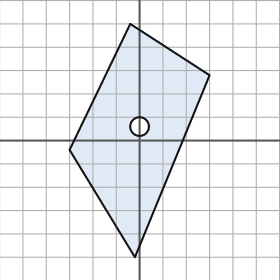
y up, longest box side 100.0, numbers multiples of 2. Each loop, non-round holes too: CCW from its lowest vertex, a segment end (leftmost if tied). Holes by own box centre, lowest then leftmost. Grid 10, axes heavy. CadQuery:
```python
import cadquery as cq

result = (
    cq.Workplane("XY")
    .moveTo(-2.0, -50.0)
    .lineTo(30.0, 28.0)
    .lineTo(-4.0, 50.0)
    .lineTo(-30.0, -4.0)
    .close()
    .moveTo(0.0, 6.0)
    .circle(4.0)
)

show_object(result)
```